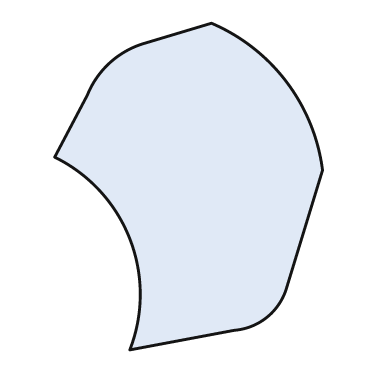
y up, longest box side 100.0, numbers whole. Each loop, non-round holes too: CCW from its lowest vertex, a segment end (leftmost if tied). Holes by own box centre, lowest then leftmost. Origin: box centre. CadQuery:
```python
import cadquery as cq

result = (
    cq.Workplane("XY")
    .moveTo(-18.0, -50.0)
    .lineTo(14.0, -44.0)
    .threePointArc((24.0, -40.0), (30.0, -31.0))
    .lineTo(41.0, 5.0)
    .threePointArc((30.0, 32.0), (7.0, 50.0))
    .lineTo(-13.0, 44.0)
    .threePointArc((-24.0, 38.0), (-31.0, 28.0))
    .lineTo(-41.0, 9.0)
    .threePointArc((-18.0, -16.0), (-18.0, -50.0))
    .close()
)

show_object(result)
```